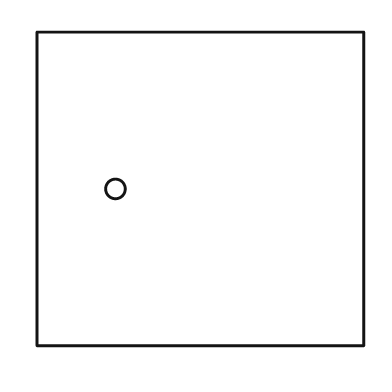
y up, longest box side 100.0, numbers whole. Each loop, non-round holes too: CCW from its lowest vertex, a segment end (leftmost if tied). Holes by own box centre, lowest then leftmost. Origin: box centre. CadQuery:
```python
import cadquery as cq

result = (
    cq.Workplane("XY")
    .moveTo(-50.0, -48.0)
    .lineTo(50.0, -48.0)
    .lineTo(50.0, 48.0)
    .lineTo(-50.0, 48.0)
    .close()
    .moveTo(-26.0, 0.0)
    .circle(3.0)
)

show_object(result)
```